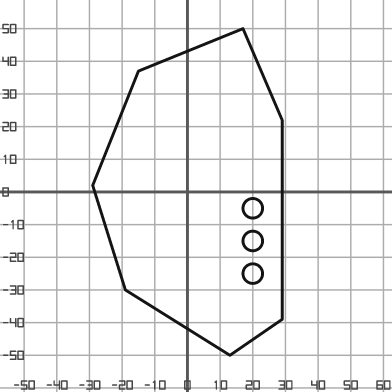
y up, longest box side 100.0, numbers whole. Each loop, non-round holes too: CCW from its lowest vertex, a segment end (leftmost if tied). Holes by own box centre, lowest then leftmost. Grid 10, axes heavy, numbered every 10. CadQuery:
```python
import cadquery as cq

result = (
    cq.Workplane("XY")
    .moveTo(13.0, -50.0)
    .lineTo(29.0, -39.0)
    .lineTo(29.0, 22.0)
    .lineTo(17.0, 50.0)
    .lineTo(-15.0, 37.0)
    .lineTo(-29.0, 2.0)
    .lineTo(-19.0, -30.0)
    .close()
    .moveTo(20.0, -25.0)
    .circle(3.0)
    .moveTo(20.0, -15.0)
    .circle(3.0)
    .moveTo(20.0, -5.0)
    .circle(3.0)
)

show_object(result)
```